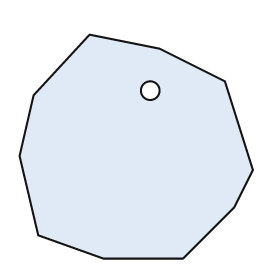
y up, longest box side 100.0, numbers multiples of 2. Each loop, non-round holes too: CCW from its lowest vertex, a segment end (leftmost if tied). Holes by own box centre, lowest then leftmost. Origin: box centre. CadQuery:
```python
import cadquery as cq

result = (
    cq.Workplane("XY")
    .moveTo(-14.0, -48.0)
    .lineTo(20.0, -48.0)
    .lineTo(42.0, -26.0)
    .lineTo(50.0, -10.0)
    .lineTo(38.0, 28.0)
    .lineTo(10.0, 42.0)
    .lineTo(-20.0, 48.0)
    .lineTo(-44.0, 22.0)
    .lineTo(-50.0, -4.0)
    .lineTo(-42.0, -38.0)
    .close()
    .moveTo(6.0, 24.0)
    .circle(4.0)
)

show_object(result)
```